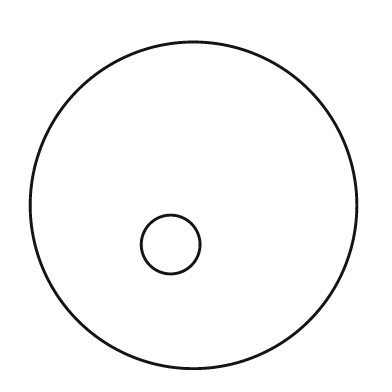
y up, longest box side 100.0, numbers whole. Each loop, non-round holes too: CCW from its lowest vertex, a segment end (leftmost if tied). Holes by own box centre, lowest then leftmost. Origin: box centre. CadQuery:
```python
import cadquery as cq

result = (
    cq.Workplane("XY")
    .moveTo(0.0, 0.0)
    .circle(50.0)
    .moveTo(-7.0, -12.0)
    .circle(9.0)
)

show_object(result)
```